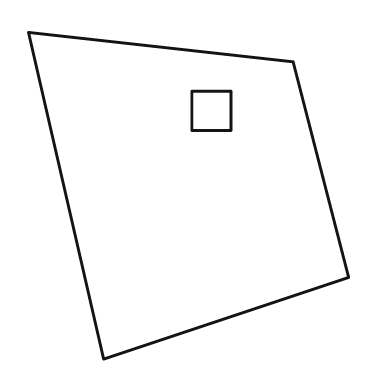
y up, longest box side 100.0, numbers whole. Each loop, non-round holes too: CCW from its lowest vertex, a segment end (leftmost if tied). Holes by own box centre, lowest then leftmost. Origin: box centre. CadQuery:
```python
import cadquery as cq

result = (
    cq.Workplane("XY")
    .moveTo(-26.0, -50.0)
    .lineTo(49.0, -25.0)
    .lineTo(32.0, 41.0)
    .lineTo(-49.0, 50.0)
    .close()
    .moveTo(1.0, 20.0)
    .lineTo(13.0, 20.0)
    .lineTo(13.0, 32.0)
    .lineTo(1.0, 32.0)
    .close()
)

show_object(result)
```